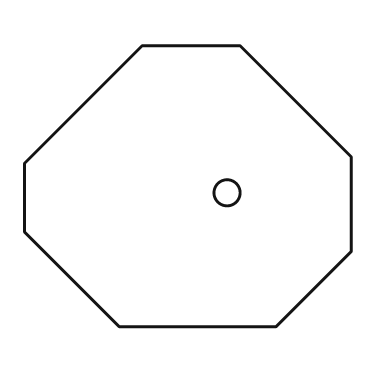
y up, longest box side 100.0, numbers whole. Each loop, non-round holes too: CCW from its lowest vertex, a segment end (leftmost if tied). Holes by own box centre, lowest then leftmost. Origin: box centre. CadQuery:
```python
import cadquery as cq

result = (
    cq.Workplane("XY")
    .moveTo(-21.0, -43.0)
    .lineTo(27.0, -43.0)
    .lineTo(50.0, -20.0)
    .lineTo(50.0, 9.0)
    .lineTo(16.0, 43.0)
    .lineTo(-14.0, 43.0)
    .lineTo(-50.0, 7.0)
    .lineTo(-50.0, -14.0)
    .close()
    .moveTo(12.0, -2.0)
    .circle(4.0)
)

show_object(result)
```